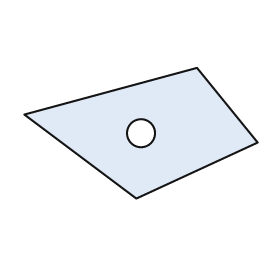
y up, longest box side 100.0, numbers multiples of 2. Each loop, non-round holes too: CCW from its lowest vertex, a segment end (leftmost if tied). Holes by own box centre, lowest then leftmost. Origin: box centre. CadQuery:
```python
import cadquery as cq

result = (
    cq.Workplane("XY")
    .moveTo(-2.0, -28.0)
    .lineTo(50.0, -4.0)
    .lineTo(24.0, 28.0)
    .lineTo(-50.0, 8.0)
    .close()
    .moveTo(0.0, 0.0)
    .circle(6.0)
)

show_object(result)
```